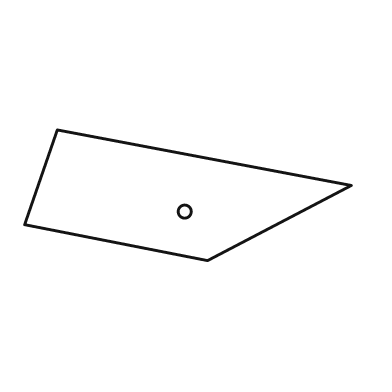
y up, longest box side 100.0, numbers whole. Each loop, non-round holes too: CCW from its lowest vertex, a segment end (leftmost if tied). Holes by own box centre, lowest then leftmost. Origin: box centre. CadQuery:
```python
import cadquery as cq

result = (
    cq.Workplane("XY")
    .moveTo(6.0, -20.0)
    .lineTo(50.0, 3.0)
    .lineTo(-40.0, 20.0)
    .lineTo(-50.0, -9.0)
    .close()
    .moveTo(-1.0, -5.0)
    .circle(2.0)
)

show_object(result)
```